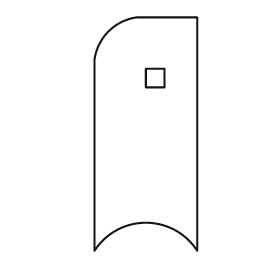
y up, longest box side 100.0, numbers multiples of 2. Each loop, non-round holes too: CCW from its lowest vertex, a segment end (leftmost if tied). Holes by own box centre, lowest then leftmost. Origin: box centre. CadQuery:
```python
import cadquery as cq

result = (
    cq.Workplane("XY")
    .moveTo(-22.0, -50.0)
    .threePointArc((0.0, -38.0), (22.0, -50.0))
    .lineTo(22.0, 50.0)
    .lineTo(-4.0, 50.0)
    .threePointArc((-16.0, 44.0), (-22.0, 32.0))
    .close()
    .moveTo(0.0, 20.0)
    .lineTo(8.0, 20.0)
    .lineTo(8.0, 28.0)
    .lineTo(0.0, 28.0)
    .close()
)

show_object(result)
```